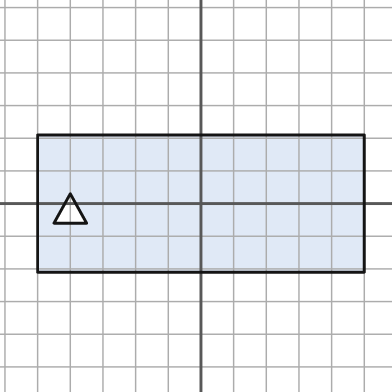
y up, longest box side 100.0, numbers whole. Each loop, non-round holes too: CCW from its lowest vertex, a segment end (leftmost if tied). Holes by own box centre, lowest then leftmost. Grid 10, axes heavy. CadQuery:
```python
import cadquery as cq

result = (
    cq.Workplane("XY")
    .moveTo(-50.0, -21.0)
    .lineTo(50.0, -21.0)
    .lineTo(50.0, 21.0)
    .lineTo(-50.0, 21.0)
    .close()
    .moveTo(-45.0, -6.0)
    .lineTo(-35.0, -6.0)
    .lineTo(-40.0, 3.0)
    .close()
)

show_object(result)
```